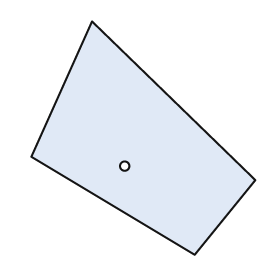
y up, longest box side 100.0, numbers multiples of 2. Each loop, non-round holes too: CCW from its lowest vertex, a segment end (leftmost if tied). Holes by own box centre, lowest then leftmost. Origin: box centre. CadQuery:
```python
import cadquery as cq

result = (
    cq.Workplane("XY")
    .moveTo(22.0, -50.0)
    .lineTo(48.0, -18.0)
    .lineTo(-22.0, 50.0)
    .lineTo(-48.0, -8.0)
    .close()
    .moveTo(-8.0, -12.0)
    .circle(2.0)
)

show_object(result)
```